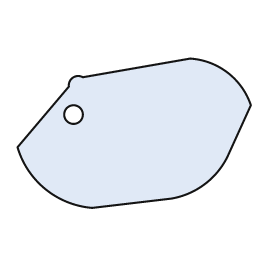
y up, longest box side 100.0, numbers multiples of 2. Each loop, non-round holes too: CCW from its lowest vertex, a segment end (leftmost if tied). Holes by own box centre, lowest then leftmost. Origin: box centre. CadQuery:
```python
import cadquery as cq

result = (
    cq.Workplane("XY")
    .moveTo(-18.0, -32.0)
    .lineTo(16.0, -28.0)
    .threePointArc((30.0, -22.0), (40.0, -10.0))
    .lineTo(50.0, 12.0)
    .threePointArc((40.0, 26.0), (24.0, 32.0))
    .lineTo(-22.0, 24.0)
    .threePointArc((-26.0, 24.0), (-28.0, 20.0))
    .lineTo(-50.0, -6.0)
    .threePointArc((-38.0, -24.0), (-18.0, -32.0))
    .close()
    .moveTo(-26.0, 8.0)
    .circle(4.0)
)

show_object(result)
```